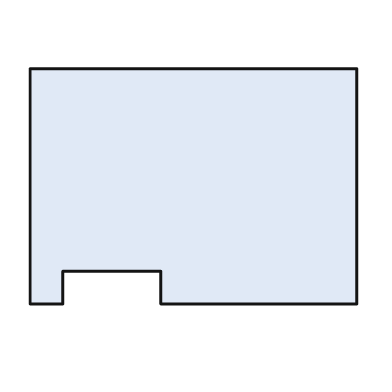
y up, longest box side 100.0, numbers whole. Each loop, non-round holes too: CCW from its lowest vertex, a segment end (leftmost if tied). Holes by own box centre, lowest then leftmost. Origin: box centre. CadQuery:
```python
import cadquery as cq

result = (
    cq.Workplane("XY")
    .moveTo(-50.0, -36.0)
    .lineTo(-40.0, -36.0)
    .lineTo(-40.0, -26.0)
    .lineTo(-10.0, -26.0)
    .lineTo(-10.0, -36.0)
    .lineTo(50.0, -36.0)
    .lineTo(50.0, 36.0)
    .lineTo(-50.0, 36.0)
    .close()
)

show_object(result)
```